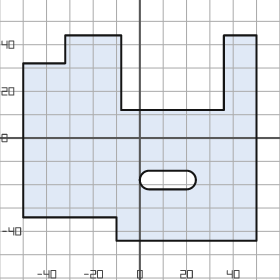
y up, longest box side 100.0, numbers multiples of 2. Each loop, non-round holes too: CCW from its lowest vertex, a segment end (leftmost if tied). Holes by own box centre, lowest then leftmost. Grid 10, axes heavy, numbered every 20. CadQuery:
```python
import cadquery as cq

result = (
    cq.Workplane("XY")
    .moveTo(-10.0, -44.0)
    .lineTo(50.0, -44.0)
    .lineTo(50.0, 44.0)
    .lineTo(36.0, 44.0)
    .lineTo(36.0, 12.0)
    .lineTo(-8.0, 12.0)
    .lineTo(-8.0, 44.0)
    .lineTo(-32.0, 44.0)
    .lineTo(-32.0, 32.0)
    .lineTo(-50.0, 32.0)
    .lineTo(-50.0, -34.0)
    .lineTo(-10.0, -34.0)
    .close()
    .moveTo(4.0, -22.0)
    .lineTo(20.0, -22.0)
    .threePointArc((24.0, -18.0), (20.0, -14.0))
    .lineTo(4.0, -14.0)
    .threePointArc((0.0, -18.0), (4.0, -22.0))
    .close()
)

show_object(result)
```